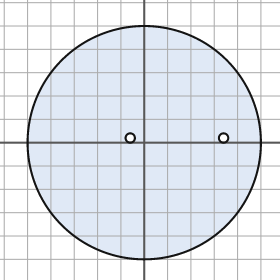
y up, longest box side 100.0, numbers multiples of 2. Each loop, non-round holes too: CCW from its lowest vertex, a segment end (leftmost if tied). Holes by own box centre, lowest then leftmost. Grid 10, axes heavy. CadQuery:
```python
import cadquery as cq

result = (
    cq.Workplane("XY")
    .moveTo(0.0, 0.0)
    .circle(50.0)
    .moveTo(-6.0, 2.0)
    .circle(2.0)
    .moveTo(34.0, 2.0)
    .circle(2.0)
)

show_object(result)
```